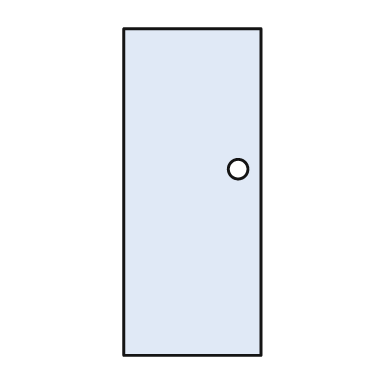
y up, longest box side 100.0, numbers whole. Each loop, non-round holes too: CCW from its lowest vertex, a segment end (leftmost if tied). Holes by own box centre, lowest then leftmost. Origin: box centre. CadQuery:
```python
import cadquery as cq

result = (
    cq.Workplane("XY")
    .moveTo(-21.0, -50.0)
    .lineTo(21.0, -50.0)
    .lineTo(21.0, 50.0)
    .lineTo(-21.0, 50.0)
    .close()
    .moveTo(14.0, 7.0)
    .circle(3.0)
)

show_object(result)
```